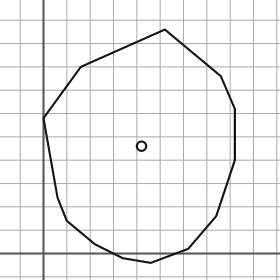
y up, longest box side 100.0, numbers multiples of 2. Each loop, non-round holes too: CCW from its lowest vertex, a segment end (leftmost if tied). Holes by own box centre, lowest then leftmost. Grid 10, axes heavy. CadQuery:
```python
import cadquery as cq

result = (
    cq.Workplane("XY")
    .moveTo(46.0, -4.0)
    .lineTo(62.0, 2.0)
    .lineTo(74.0, 16.0)
    .lineTo(82.0, 40.0)
    .lineTo(82.0, 62.0)
    .lineTo(76.0, 76.0)
    .lineTo(52.0, 96.0)
    .lineTo(16.0, 80.0)
    .lineTo(0.0, 58.0)
    .lineTo(6.0, 24.0)
    .lineTo(10.0, 14.0)
    .lineTo(22.0, 4.0)
    .lineTo(34.0, -2.0)
    .close()
    .moveTo(42.0, 46.0)
    .circle(2.0)
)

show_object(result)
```